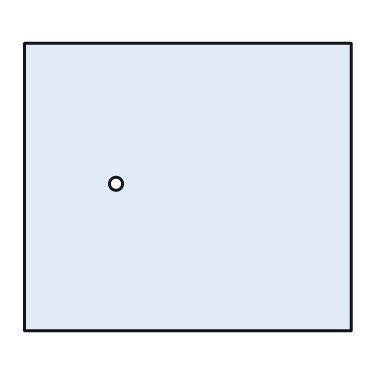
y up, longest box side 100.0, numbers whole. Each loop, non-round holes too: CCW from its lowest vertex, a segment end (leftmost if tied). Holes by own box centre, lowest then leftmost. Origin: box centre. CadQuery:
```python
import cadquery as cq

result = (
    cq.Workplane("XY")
    .moveTo(-50.0, -44.0)
    .lineTo(50.0, -44.0)
    .lineTo(50.0, 44.0)
    .lineTo(-50.0, 44.0)
    .close()
    .moveTo(-22.0, 1.0)
    .circle(2.0)
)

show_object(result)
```